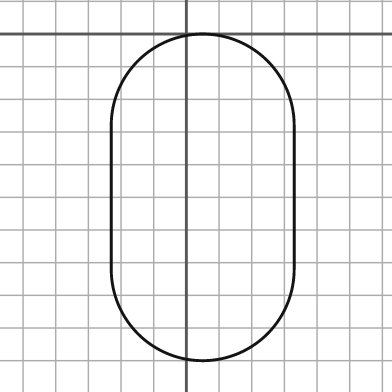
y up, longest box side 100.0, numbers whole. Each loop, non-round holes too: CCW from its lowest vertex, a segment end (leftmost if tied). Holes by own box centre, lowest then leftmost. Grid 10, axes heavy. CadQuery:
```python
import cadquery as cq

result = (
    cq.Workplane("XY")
    .moveTo(-23.0, -72.0)
    .threePointArc((5.0, -100.0), (33.0, -72.0))
    .lineTo(33.0, -28.0)
    .threePointArc((5.0, 0.0), (-23.0, -28.0))
    .close()
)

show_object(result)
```